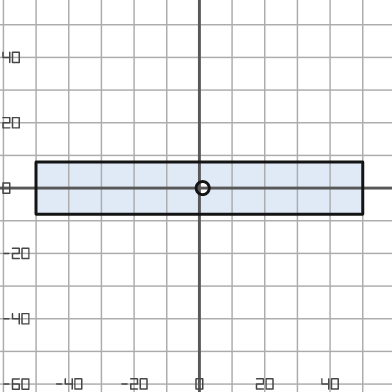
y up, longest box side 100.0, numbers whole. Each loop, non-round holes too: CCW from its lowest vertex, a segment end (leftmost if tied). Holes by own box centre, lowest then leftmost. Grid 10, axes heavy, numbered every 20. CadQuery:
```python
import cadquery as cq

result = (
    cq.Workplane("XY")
    .moveTo(-50.0, -8.0)
    .lineTo(50.0, -8.0)
    .lineTo(50.0, 8.0)
    .lineTo(-50.0, 8.0)
    .close()
    .moveTo(1.0, 0.0)
    .circle(2.0)
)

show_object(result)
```